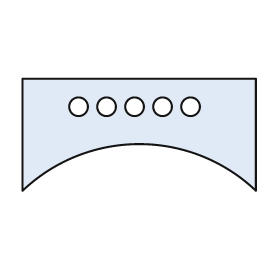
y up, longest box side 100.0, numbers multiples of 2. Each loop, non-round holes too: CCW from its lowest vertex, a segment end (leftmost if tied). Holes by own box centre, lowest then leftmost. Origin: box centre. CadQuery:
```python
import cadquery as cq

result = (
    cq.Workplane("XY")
    .moveTo(-50.0, -24.0)
    .threePointArc((0.0, -4.0), (50.0, -24.0))
    .lineTo(50.0, 24.0)
    .lineTo(-50.0, 24.0)
    .close()
    .moveTo(-26.0, 12.0)
    .circle(4.0)
    .moveTo(-14.0, 12.0)
    .circle(4.0)
    .moveTo(-2.0, 12.0)
    .circle(4.0)
    .moveTo(10.0, 12.0)
    .circle(4.0)
    .moveTo(22.0, 12.0)
    .circle(4.0)
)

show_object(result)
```